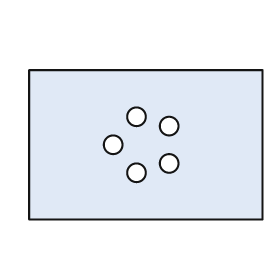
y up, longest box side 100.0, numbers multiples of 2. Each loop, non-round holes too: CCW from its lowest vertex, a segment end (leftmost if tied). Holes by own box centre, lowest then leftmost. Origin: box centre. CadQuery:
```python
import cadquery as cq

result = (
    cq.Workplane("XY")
    .moveTo(-50.0, -32.0)
    .lineTo(50.0, -32.0)
    .lineTo(50.0, 32.0)
    .lineTo(-50.0, 32.0)
    .close()
    .moveTo(-4.0, -12.0)
    .circle(4.0)
    .moveTo(10.0, -8.0)
    .circle(4.0)
    .moveTo(-14.0, 0.0)
    .circle(4.0)
    .moveTo(10.0, 8.0)
    .circle(4.0)
    .moveTo(-4.0, 12.0)
    .circle(4.0)
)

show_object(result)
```